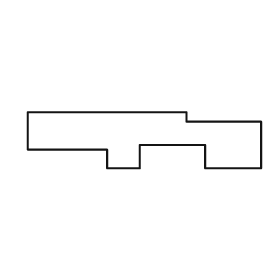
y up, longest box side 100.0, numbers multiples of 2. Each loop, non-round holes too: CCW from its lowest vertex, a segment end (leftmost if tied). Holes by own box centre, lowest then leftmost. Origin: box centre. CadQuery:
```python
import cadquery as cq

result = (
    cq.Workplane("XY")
    .moveTo(-16.0, -12.0)
    .lineTo(-2.0, -12.0)
    .lineTo(-2.0, -2.0)
    .lineTo(26.0, -2.0)
    .lineTo(26.0, -12.0)
    .lineTo(50.0, -12.0)
    .lineTo(50.0, 8.0)
    .lineTo(18.0, 8.0)
    .lineTo(18.0, 12.0)
    .lineTo(-50.0, 12.0)
    .lineTo(-50.0, -4.0)
    .lineTo(-16.0, -4.0)
    .close()
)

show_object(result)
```